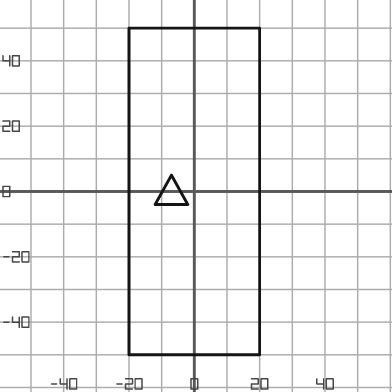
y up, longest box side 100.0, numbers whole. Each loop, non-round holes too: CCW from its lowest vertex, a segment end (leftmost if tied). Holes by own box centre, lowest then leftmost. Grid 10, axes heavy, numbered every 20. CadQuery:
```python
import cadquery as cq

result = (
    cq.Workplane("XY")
    .moveTo(-20.0, -50.0)
    .lineTo(20.0, -50.0)
    .lineTo(20.0, 50.0)
    .lineTo(-20.0, 50.0)
    .close()
    .moveTo(-12.0, -4.0)
    .lineTo(-2.0, -4.0)
    .lineTo(-7.0, 5.0)
    .close()
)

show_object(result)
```